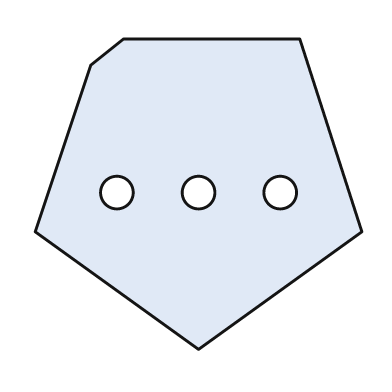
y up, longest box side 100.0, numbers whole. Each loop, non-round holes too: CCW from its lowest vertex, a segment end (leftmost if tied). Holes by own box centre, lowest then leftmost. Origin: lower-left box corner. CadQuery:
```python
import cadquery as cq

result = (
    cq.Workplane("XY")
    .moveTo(50.0, 0.0)
    .lineTo(100.0, 36.0)
    .lineTo(81.0, 95.0)
    .lineTo(27.0, 95.0)
    .lineTo(17.0, 87.0)
    .lineTo(0.0, 36.0)
    .close()
    .moveTo(25.0, 48.0)
    .circle(5.0)
    .moveTo(50.0, 48.0)
    .circle(5.0)
    .moveTo(75.0, 48.0)
    .circle(5.0)
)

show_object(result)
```